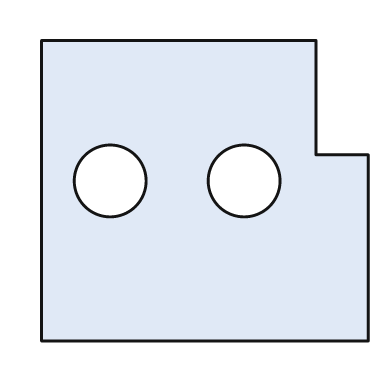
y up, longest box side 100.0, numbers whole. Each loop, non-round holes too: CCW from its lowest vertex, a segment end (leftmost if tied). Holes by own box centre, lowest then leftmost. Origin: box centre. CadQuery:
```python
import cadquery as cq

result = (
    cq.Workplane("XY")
    .moveTo(-50.0, -46.0)
    .lineTo(50.0, -46.0)
    .lineTo(50.0, 11.0)
    .lineTo(34.0, 11.0)
    .lineTo(34.0, 46.0)
    .lineTo(-50.0, 46.0)
    .close()
    .moveTo(-29.0, 3.0)
    .circle(11.0)
    .moveTo(12.0, 3.0)
    .circle(11.0)
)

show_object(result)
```